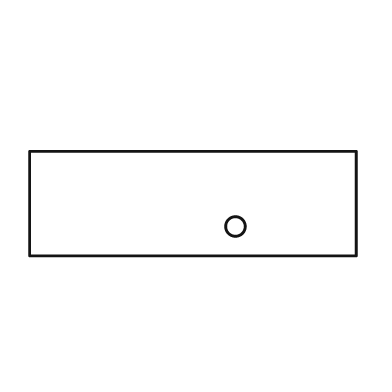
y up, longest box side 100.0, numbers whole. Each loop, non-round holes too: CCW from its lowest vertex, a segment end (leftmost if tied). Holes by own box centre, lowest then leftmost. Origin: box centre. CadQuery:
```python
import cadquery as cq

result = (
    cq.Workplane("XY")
    .moveTo(-50.0, -16.0)
    .lineTo(50.0, -16.0)
    .lineTo(50.0, 16.0)
    .lineTo(-50.0, 16.0)
    .close()
    .moveTo(13.0, -7.0)
    .circle(3.0)
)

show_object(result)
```